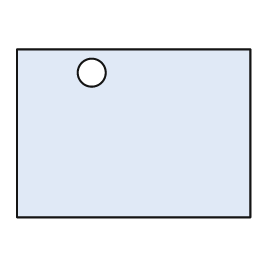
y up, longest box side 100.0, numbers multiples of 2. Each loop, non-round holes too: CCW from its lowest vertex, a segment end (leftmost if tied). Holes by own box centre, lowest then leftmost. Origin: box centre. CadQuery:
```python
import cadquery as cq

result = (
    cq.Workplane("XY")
    .moveTo(-50.0, -36.0)
    .lineTo(50.0, -36.0)
    .lineTo(50.0, 36.0)
    .lineTo(-50.0, 36.0)
    .close()
    .moveTo(-18.0, 26.0)
    .circle(6.0)
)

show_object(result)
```